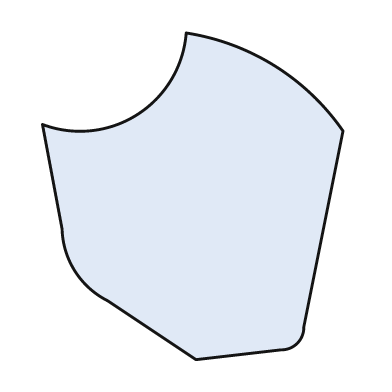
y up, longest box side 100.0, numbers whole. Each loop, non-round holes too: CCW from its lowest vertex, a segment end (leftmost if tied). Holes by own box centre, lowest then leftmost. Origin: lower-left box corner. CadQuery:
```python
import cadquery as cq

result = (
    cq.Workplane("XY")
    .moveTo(47.0, 0.0)
    .lineTo(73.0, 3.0)
    .threePointArc((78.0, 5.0), (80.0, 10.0))
    .lineTo(92.0, 70.0)
    .threePointArc((71.0, 90.0), (44.0, 100.0))
    .threePointArc((29.0, 75.0), (0.0, 72.0))
    .lineTo(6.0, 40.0)
    .threePointArc((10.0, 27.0), (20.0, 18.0))
    .close()
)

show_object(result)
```